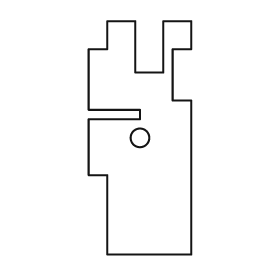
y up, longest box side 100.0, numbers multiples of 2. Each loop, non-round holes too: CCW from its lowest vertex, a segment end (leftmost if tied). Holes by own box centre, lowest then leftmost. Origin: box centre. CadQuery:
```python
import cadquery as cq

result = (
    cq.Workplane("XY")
    .moveTo(-14.0, -50.0)
    .lineTo(22.0, -50.0)
    .lineTo(22.0, 16.0)
    .lineTo(14.0, 16.0)
    .lineTo(14.0, 38.0)
    .lineTo(22.0, 38.0)
    .lineTo(22.0, 50.0)
    .lineTo(10.0, 50.0)
    .lineTo(10.0, 28.0)
    .lineTo(-2.0, 28.0)
    .lineTo(-2.0, 50.0)
    .lineTo(-14.0, 50.0)
    .lineTo(-14.0, 38.0)
    .lineTo(-22.0, 38.0)
    .lineTo(-22.0, 12.0)
    .lineTo(0.0, 12.0)
    .lineTo(0.0, 8.0)
    .lineTo(-22.0, 8.0)
    .lineTo(-22.0, -16.0)
    .lineTo(-14.0, -16.0)
    .close()
    .moveTo(0.0, 0.0)
    .circle(4.0)
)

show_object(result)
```